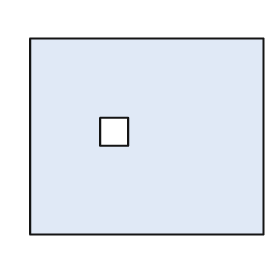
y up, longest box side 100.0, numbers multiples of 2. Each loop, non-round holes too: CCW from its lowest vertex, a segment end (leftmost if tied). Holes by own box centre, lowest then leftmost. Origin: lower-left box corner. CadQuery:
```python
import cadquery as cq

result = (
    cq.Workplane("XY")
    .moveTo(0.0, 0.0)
    .lineTo(100.0, 0.0)
    .lineTo(100.0, 84.0)
    .lineTo(0.0, 84.0)
    .close()
    .moveTo(30.0, 38.0)
    .lineTo(42.0, 38.0)
    .lineTo(42.0, 50.0)
    .lineTo(30.0, 50.0)
    .close()
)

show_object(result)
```